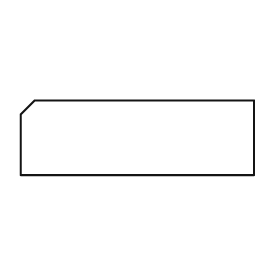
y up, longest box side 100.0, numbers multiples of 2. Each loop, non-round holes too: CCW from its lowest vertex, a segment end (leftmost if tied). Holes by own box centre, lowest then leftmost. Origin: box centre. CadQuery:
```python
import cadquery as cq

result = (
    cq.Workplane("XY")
    .moveTo(-50.0, -16.0)
    .lineTo(50.0, -16.0)
    .lineTo(50.0, 16.0)
    .lineTo(-44.0, 16.0)
    .lineTo(-50.0, 10.0)
    .close()
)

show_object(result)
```